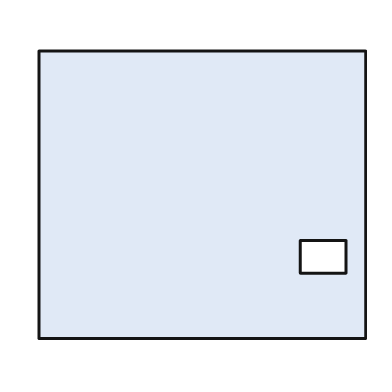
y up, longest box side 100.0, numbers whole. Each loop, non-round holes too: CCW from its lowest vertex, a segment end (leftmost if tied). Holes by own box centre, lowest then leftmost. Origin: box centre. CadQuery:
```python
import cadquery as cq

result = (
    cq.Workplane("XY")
    .moveTo(-50.0, -44.0)
    .lineTo(50.0, -44.0)
    .lineTo(50.0, 44.0)
    .lineTo(-50.0, 44.0)
    .close()
    .moveTo(30.0, -24.0)
    .lineTo(44.0, -24.0)
    .lineTo(44.0, -14.0)
    .lineTo(30.0, -14.0)
    .close()
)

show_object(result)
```